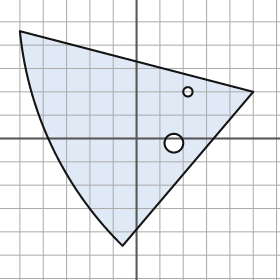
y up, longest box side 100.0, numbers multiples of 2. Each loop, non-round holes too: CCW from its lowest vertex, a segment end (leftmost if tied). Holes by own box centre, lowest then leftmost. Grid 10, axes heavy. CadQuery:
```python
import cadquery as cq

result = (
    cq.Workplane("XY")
    .moveTo(-6.0, -46.0)
    .lineTo(50.0, 20.0)
    .lineTo(-50.0, 46.0)
    .threePointArc((-36.0, -4.0), (-6.0, -46.0))
    .close()
    .moveTo(16.0, -2.0)
    .circle(4.0)
    .moveTo(22.0, 20.0)
    .circle(2.0)
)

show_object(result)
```